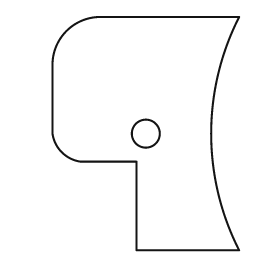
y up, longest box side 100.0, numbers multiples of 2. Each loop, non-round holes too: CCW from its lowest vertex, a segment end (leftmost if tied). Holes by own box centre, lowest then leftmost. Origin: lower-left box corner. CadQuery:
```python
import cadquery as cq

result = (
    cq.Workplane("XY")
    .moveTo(36.0, 0.0)
    .lineTo(80.0, 0.0)
    .threePointArc((68.0, 50.0), (80.0, 100.0))
    .lineTo(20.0, 100.0)
    .threePointArc((6.0, 94.0), (0.0, 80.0))
    .lineTo(0.0, 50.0)
    .threePointArc((4.0, 42.0), (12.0, 38.0))
    .lineTo(36.0, 38.0)
    .close()
    .moveTo(40.0, 50.0)
    .circle(6.0)
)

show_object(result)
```